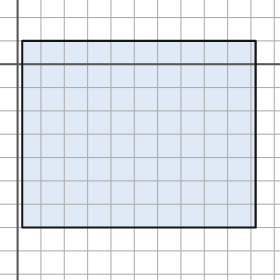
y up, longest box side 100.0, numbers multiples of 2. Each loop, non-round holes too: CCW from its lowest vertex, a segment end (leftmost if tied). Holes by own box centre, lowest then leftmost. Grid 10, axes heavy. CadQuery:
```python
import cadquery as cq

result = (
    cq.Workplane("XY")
    .moveTo(2.0, -70.0)
    .lineTo(102.0, -70.0)
    .lineTo(102.0, 10.0)
    .lineTo(2.0, 10.0)
    .close()
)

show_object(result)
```